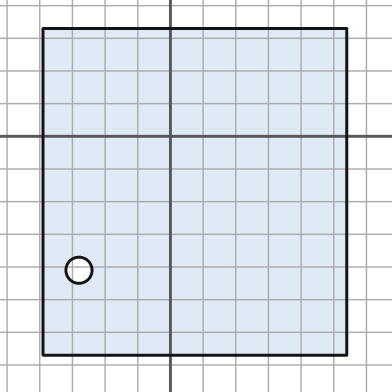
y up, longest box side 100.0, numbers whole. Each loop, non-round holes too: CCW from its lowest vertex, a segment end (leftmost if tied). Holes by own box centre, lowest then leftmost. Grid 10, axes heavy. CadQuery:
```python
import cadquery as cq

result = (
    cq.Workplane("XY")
    .moveTo(-39.0, -67.0)
    .lineTo(54.0, -67.0)
    .lineTo(54.0, 33.0)
    .lineTo(-39.0, 33.0)
    .close()
    .moveTo(-28.0, -41.0)
    .circle(4.0)
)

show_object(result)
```